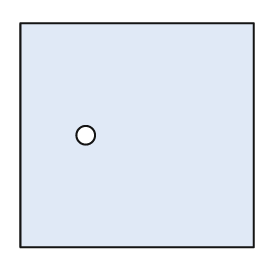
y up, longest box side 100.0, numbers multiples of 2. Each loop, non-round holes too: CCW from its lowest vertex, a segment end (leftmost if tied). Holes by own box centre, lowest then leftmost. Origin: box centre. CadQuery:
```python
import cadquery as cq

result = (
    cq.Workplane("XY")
    .moveTo(-50.0, -48.0)
    .lineTo(50.0, -48.0)
    .lineTo(50.0, 48.0)
    .lineTo(-50.0, 48.0)
    .close()
    .moveTo(-22.0, 0.0)
    .circle(4.0)
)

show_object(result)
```